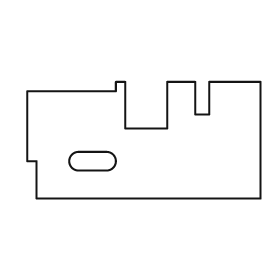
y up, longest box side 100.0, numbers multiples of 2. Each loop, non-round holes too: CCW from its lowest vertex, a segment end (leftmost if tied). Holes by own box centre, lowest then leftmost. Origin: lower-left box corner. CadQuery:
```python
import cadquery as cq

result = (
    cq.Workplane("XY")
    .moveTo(4.0, 0.0)
    .lineTo(100.0, 0.0)
    .lineTo(100.0, 50.0)
    .lineTo(78.0, 50.0)
    .lineTo(78.0, 36.0)
    .lineTo(72.0, 36.0)
    .lineTo(72.0, 50.0)
    .lineTo(60.0, 50.0)
    .lineTo(60.0, 30.0)
    .lineTo(42.0, 30.0)
    .lineTo(42.0, 50.0)
    .lineTo(38.0, 50.0)
    .lineTo(38.0, 46.0)
    .lineTo(0.0, 46.0)
    .lineTo(0.0, 16.0)
    .lineTo(4.0, 16.0)
    .close()
    .moveTo(22.0, 12.0)
    .lineTo(34.0, 12.0)
    .threePointArc((38.0, 16.0), (34.0, 20.0))
    .lineTo(22.0, 20.0)
    .threePointArc((18.0, 16.0), (22.0, 12.0))
    .close()
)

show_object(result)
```